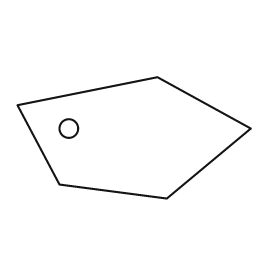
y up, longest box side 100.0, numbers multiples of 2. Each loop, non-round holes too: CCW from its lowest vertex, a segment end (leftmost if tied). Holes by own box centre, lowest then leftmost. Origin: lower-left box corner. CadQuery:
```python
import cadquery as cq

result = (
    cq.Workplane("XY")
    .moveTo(64.0, 0.0)
    .lineTo(100.0, 30.0)
    .lineTo(60.0, 52.0)
    .lineTo(0.0, 40.0)
    .lineTo(18.0, 6.0)
    .close()
    .moveTo(22.0, 30.0)
    .circle(4.0)
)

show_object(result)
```